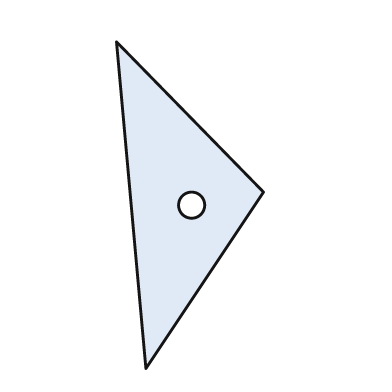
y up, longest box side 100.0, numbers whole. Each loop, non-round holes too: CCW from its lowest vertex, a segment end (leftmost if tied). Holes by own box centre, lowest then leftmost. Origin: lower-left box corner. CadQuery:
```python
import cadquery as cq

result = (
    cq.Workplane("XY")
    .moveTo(9.0, 0.0)
    .lineTo(45.0, 54.0)
    .lineTo(0.0, 100.0)
    .close()
    .moveTo(23.0, 50.0)
    .circle(4.0)
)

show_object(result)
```